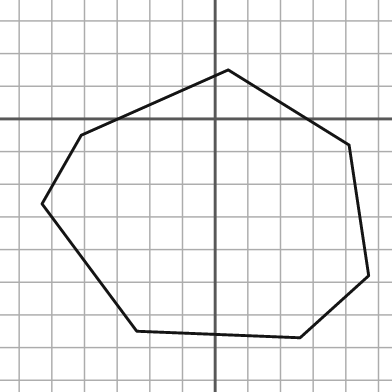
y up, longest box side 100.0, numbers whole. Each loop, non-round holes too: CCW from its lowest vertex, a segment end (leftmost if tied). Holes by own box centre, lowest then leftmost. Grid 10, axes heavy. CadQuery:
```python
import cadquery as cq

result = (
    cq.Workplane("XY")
    .moveTo(26.0, -67.0)
    .lineTo(47.0, -48.0)
    .lineTo(41.0, -8.0)
    .lineTo(4.0, 15.0)
    .lineTo(-41.0, -5.0)
    .lineTo(-53.0, -26.0)
    .lineTo(-24.0, -65.0)
    .close()
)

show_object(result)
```